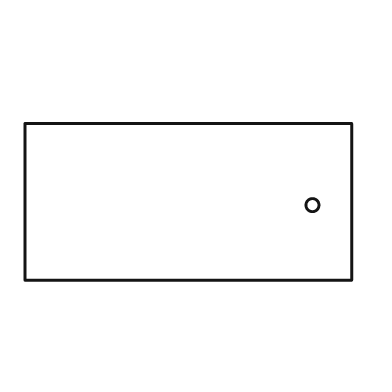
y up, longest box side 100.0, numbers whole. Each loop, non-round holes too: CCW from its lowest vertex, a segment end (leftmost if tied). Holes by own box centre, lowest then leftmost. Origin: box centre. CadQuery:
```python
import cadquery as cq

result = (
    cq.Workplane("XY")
    .moveTo(-50.0, -24.0)
    .lineTo(50.0, -24.0)
    .lineTo(50.0, 24.0)
    .lineTo(-50.0, 24.0)
    .close()
    .moveTo(38.0, -1.0)
    .circle(2.0)
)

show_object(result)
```